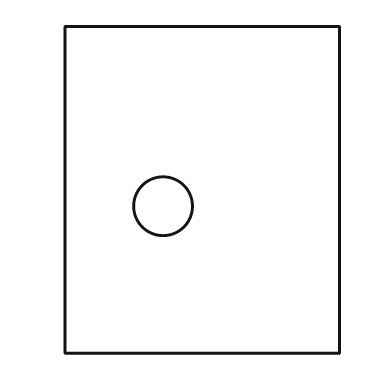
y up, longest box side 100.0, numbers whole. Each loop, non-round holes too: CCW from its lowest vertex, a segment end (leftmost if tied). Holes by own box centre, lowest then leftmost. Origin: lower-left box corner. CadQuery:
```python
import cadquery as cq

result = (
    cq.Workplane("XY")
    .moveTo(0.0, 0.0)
    .lineTo(84.0, 0.0)
    .lineTo(84.0, 100.0)
    .lineTo(0.0, 100.0)
    .close()
    .moveTo(30.0, 45.0)
    .circle(9.0)
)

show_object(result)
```